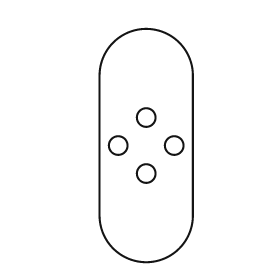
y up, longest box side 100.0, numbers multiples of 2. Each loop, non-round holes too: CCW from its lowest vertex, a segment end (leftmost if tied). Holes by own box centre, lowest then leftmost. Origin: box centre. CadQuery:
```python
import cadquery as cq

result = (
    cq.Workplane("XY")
    .moveTo(-20.0, -30.0)
    .threePointArc((0.0, -50.0), (20.0, -30.0))
    .lineTo(20.0, 30.0)
    .threePointArc((0.0, 50.0), (-20.0, 30.0))
    .close()
    .moveTo(0.0, -12.0)
    .circle(4.0)
    .moveTo(-12.0, 0.0)
    .circle(4.0)
    .moveTo(12.0, 0.0)
    .circle(4.0)
    .moveTo(0.0, 12.0)
    .circle(4.0)
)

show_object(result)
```